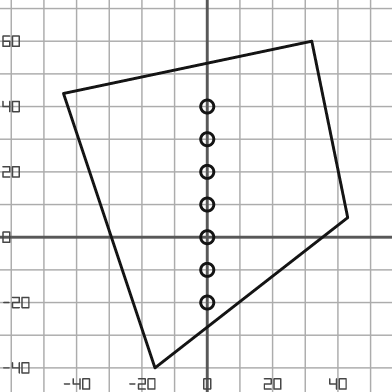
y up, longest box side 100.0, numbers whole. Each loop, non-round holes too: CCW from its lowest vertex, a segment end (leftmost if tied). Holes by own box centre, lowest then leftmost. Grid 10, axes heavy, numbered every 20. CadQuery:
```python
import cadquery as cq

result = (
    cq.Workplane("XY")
    .moveTo(-16.0, -40.0)
    .lineTo(43.0, 6.0)
    .lineTo(32.0, 60.0)
    .lineTo(-44.0, 44.0)
    .close()
    .moveTo(0.0, -20.0)
    .circle(2.0)
    .moveTo(0.0, -10.0)
    .circle(2.0)
    .moveTo(0.0, 0.0)
    .circle(2.0)
    .moveTo(0.0, 10.0)
    .circle(2.0)
    .moveTo(0.0, 20.0)
    .circle(2.0)
    .moveTo(0.0, 30.0)
    .circle(2.0)
    .moveTo(0.0, 40.0)
    .circle(2.0)
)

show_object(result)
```